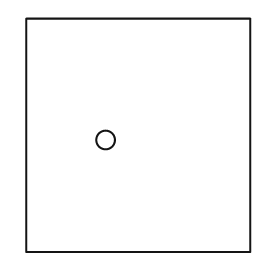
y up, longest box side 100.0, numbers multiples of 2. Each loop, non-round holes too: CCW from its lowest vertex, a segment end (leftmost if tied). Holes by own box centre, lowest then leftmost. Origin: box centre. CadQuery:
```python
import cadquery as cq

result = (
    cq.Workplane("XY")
    .moveTo(-48.0, -50.0)
    .lineTo(48.0, -50.0)
    .lineTo(48.0, 50.0)
    .lineTo(-48.0, 50.0)
    .close()
    .moveTo(-14.0, -2.0)
    .circle(4.0)
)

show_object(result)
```